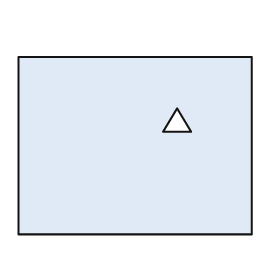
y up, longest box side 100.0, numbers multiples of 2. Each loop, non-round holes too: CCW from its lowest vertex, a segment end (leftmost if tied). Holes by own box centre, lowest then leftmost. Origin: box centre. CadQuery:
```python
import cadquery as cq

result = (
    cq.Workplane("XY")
    .moveTo(-50.0, -38.0)
    .lineTo(50.0, -38.0)
    .lineTo(50.0, 38.0)
    .lineTo(-50.0, 38.0)
    .close()
    .moveTo(12.0, 6.0)
    .lineTo(24.0, 6.0)
    .lineTo(18.0, 16.0)
    .close()
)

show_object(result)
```